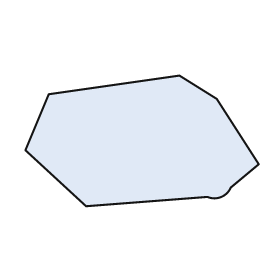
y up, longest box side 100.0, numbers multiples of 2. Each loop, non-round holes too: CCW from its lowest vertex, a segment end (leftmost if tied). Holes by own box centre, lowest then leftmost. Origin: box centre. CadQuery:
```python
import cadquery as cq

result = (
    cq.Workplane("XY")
    .moveTo(-24.0, -28.0)
    .lineTo(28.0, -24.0)
    .threePointArc((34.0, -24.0), (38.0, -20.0))
    .lineTo(50.0, -10.0)
    .lineTo(32.0, 18.0)
    .lineTo(16.0, 28.0)
    .lineTo(-40.0, 20.0)
    .lineTo(-50.0, -4.0)
    .close()
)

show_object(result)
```